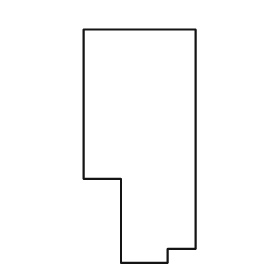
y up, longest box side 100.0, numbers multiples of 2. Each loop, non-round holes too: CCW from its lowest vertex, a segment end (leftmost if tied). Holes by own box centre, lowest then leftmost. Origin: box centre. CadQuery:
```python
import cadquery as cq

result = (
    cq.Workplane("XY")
    .moveTo(-8.0, -50.0)
    .lineTo(12.0, -50.0)
    .lineTo(12.0, -44.0)
    .lineTo(24.0, -44.0)
    .lineTo(24.0, 50.0)
    .lineTo(-24.0, 50.0)
    .lineTo(-24.0, -14.0)
    .lineTo(-8.0, -14.0)
    .close()
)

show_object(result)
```